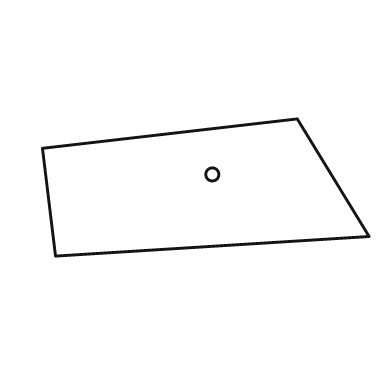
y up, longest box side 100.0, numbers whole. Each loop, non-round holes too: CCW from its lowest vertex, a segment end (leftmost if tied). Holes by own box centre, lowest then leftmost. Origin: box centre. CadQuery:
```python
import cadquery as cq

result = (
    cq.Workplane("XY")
    .moveTo(-46.0, -21.0)
    .lineTo(50.0, -15.0)
    .lineTo(28.0, 21.0)
    .lineTo(-50.0, 12.0)
    .close()
    .moveTo(2.0, 4.0)
    .circle(2.0)
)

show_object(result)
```